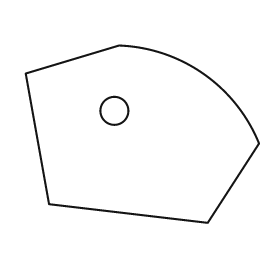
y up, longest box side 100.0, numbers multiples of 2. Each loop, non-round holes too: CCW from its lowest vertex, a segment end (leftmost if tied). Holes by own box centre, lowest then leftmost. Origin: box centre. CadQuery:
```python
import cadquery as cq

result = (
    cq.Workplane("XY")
    .moveTo(28.0, -38.0)
    .lineTo(50.0, -4.0)
    .threePointArc((26.0, 26.0), (-10.0, 38.0))
    .lineTo(-50.0, 26.0)
    .lineTo(-40.0, -30.0)
    .close()
    .moveTo(-12.0, 10.0)
    .circle(6.0)
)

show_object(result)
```